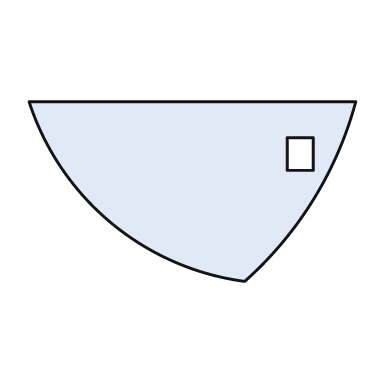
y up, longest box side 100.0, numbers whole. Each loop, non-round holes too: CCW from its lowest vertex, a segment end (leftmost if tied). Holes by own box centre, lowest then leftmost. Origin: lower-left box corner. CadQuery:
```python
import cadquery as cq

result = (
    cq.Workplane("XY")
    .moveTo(66.0, 0.0)
    .threePointArc((87.0, 25.0), (100.0, 55.0))
    .lineTo(0.0, 55.0)
    .threePointArc((25.0, 18.0), (66.0, 0.0))
    .close()
    .moveTo(79.0, 34.0)
    .lineTo(87.0, 34.0)
    .lineTo(87.0, 44.0)
    .lineTo(79.0, 44.0)
    .close()
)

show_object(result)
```